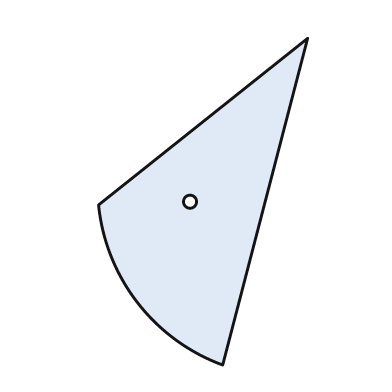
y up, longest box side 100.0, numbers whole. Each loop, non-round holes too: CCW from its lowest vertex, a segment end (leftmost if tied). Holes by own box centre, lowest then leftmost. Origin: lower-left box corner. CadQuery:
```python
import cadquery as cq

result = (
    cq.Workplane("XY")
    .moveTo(38.0, 0.0)
    .lineTo(64.0, 100.0)
    .lineTo(0.0, 49.0)
    .threePointArc((12.0, 19.0), (38.0, 0.0))
    .close()
    .moveTo(28.0, 50.0)
    .circle(2.0)
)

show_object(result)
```